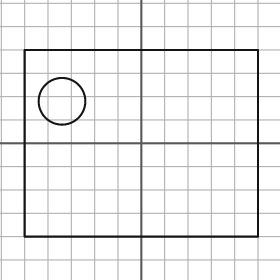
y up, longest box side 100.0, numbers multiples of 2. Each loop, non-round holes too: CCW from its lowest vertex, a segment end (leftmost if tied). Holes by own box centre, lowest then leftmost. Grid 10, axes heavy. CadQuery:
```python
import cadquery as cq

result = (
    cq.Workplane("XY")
    .moveTo(-50.0, -40.0)
    .lineTo(50.0, -40.0)
    .lineTo(50.0, 40.0)
    .lineTo(-50.0, 40.0)
    .close()
    .moveTo(-34.0, 18.0)
    .circle(10.0)
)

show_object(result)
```